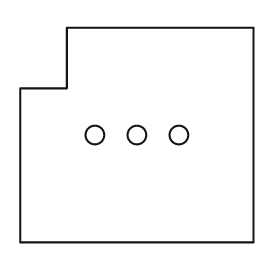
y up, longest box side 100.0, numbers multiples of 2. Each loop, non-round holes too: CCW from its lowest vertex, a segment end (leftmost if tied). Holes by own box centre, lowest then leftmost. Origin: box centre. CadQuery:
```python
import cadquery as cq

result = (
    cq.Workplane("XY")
    .moveTo(-50.0, -46.0)
    .lineTo(50.0, -46.0)
    .lineTo(50.0, 46.0)
    .lineTo(-30.0, 46.0)
    .lineTo(-30.0, 20.0)
    .lineTo(-50.0, 20.0)
    .close()
    .moveTo(-18.0, 0.0)
    .circle(4.0)
    .moveTo(0.0, 0.0)
    .circle(4.0)
    .moveTo(18.0, 0.0)
    .circle(4.0)
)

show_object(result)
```